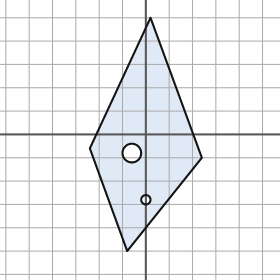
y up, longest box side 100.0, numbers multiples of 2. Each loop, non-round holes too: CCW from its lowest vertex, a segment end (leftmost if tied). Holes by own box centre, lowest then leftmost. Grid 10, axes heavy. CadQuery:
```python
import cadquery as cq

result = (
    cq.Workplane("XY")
    .moveTo(-8.0, -50.0)
    .lineTo(24.0, -10.0)
    .lineTo(2.0, 50.0)
    .lineTo(-24.0, -6.0)
    .close()
    .moveTo(0.0, -28.0)
    .circle(2.0)
    .moveTo(-6.0, -8.0)
    .circle(4.0)
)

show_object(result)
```